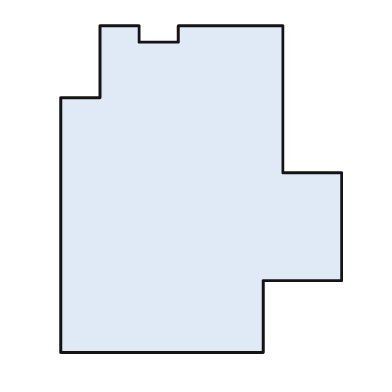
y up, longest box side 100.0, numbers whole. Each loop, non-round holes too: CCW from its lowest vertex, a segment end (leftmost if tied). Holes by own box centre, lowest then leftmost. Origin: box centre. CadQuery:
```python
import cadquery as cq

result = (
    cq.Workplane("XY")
    .moveTo(-43.0, -50.0)
    .lineTo(19.0, -50.0)
    .lineTo(19.0, -28.0)
    .lineTo(43.0, -28.0)
    .lineTo(43.0, 5.0)
    .lineTo(25.0, 5.0)
    .lineTo(25.0, 50.0)
    .lineTo(-7.0, 50.0)
    .lineTo(-7.0, 45.0)
    .lineTo(-19.0, 45.0)
    .lineTo(-19.0, 50.0)
    .lineTo(-31.0, 50.0)
    .lineTo(-31.0, 28.0)
    .lineTo(-43.0, 28.0)
    .close()
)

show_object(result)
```